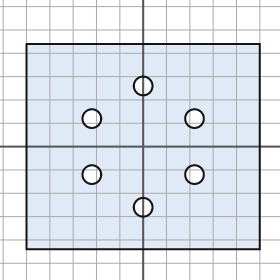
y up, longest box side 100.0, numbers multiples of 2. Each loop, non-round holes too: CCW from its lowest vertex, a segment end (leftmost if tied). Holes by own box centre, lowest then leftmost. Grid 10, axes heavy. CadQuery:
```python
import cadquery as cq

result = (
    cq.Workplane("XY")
    .moveTo(-50.0, -44.0)
    .lineTo(50.0, -44.0)
    .lineTo(50.0, 44.0)
    .lineTo(-50.0, 44.0)
    .close()
    .moveTo(0.0, -26.0)
    .circle(4.0)
    .moveTo(-22.0, -12.0)
    .circle(4.0)
    .moveTo(22.0, -12.0)
    .circle(4.0)
    .moveTo(-22.0, 12.0)
    .circle(4.0)
    .moveTo(22.0, 12.0)
    .circle(4.0)
    .moveTo(0.0, 26.0)
    .circle(4.0)
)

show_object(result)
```